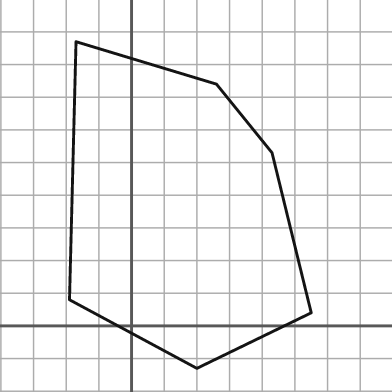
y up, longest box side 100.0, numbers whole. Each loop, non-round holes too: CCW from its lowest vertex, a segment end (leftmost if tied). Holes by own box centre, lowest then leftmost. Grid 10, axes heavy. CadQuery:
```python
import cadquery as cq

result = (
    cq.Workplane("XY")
    .moveTo(20.0, -13.0)
    .lineTo(55.0, 4.0)
    .lineTo(43.0, 53.0)
    .lineTo(26.0, 74.0)
    .lineTo(-17.0, 87.0)
    .lineTo(-19.0, 8.0)
    .close()
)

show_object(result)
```